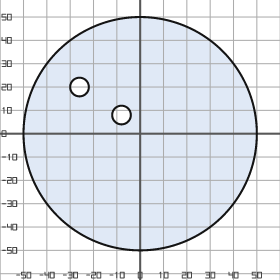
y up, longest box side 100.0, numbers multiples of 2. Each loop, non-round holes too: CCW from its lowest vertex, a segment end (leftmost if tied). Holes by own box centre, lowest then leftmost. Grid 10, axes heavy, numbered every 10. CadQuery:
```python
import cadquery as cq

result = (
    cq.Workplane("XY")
    .moveTo(0.0, 0.0)
    .circle(50.0)
    .moveTo(-8.0, 8.0)
    .circle(4.0)
    .moveTo(-26.0, 20.0)
    .circle(4.0)
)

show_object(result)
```